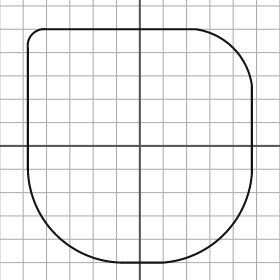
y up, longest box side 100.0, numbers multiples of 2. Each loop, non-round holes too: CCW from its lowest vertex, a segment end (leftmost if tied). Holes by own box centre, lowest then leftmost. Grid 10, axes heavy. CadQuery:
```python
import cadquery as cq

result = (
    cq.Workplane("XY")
    .moveTo(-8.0, -50.0)
    .lineTo(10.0, -50.0)
    .threePointArc((36.0, -38.0), (48.0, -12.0))
    .lineTo(48.0, 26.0)
    .threePointArc((40.0, 42.0), (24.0, 50.0))
    .lineTo(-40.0, 50.0)
    .threePointArc((-46.0, 48.0), (-48.0, 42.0))
    .lineTo(-48.0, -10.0)
    .threePointArc((-36.0, -38.0), (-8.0, -50.0))
    .close()
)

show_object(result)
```